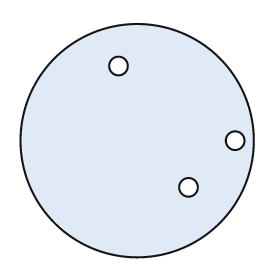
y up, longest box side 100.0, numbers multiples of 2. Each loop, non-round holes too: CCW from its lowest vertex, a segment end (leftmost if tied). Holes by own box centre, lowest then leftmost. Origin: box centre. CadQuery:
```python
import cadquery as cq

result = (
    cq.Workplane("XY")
    .moveTo(0.0, 0.0)
    .circle(50.0)
    .moveTo(22.0, -20.0)
    .circle(4.0)
    .moveTo(42.0, 0.0)
    .circle(4.0)
    .moveTo(-8.0, 32.0)
    .circle(4.0)
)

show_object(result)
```